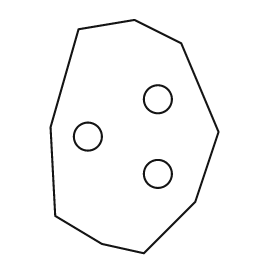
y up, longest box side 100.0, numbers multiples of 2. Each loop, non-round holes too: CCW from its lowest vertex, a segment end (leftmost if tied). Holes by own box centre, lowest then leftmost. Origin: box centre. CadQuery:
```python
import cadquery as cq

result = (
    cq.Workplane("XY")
    .moveTo(4.0, -50.0)
    .lineTo(26.0, -28.0)
    .lineTo(36.0, 2.0)
    .lineTo(20.0, 40.0)
    .lineTo(0.0, 50.0)
    .lineTo(-24.0, 46.0)
    .lineTo(-36.0, 4.0)
    .lineTo(-34.0, -34.0)
    .lineTo(-14.0, -46.0)
    .close()
    .moveTo(10.0, -16.0)
    .circle(6.0)
    .moveTo(-20.0, 0.0)
    .circle(6.0)
    .moveTo(10.0, 16.0)
    .circle(6.0)
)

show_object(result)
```